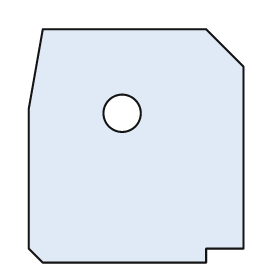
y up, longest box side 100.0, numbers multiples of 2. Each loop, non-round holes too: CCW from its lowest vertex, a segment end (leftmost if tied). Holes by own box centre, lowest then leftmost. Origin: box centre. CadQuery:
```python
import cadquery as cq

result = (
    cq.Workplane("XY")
    .moveTo(-40.0, -50.0)
    .lineTo(30.0, -50.0)
    .lineTo(30.0, -44.0)
    .lineTo(46.0, -44.0)
    .lineTo(46.0, 34.0)
    .lineTo(30.0, 50.0)
    .lineTo(-40.0, 50.0)
    .lineTo(-46.0, 16.0)
    .lineTo(-46.0, -44.0)
    .close()
    .moveTo(-6.0, 14.0)
    .circle(8.0)
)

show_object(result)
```